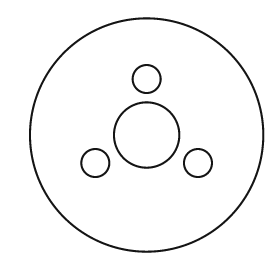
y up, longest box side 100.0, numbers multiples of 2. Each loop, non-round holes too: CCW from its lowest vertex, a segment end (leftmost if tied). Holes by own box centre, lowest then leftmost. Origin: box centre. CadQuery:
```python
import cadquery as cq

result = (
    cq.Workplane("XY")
    .moveTo(0.0, 0.0)
    .circle(50.0)
    .moveTo(-22.0, -12.0)
    .circle(6.0)
    .moveTo(22.0, -12.0)
    .circle(6.0)
    .moveTo(0.0, 0.0)
    .circle(14.0)
    .moveTo(0.0, 24.0)
    .circle(6.0)
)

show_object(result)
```